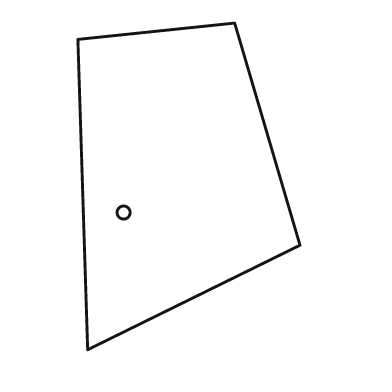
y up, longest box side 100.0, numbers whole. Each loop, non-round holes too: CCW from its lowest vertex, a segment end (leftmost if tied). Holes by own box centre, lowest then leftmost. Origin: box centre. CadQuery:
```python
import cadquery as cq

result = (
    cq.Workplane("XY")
    .moveTo(-31.0, -50.0)
    .lineTo(34.0, -18.0)
    .lineTo(14.0, 50.0)
    .lineTo(-34.0, 45.0)
    .close()
    .moveTo(-20.0, -8.0)
    .circle(2.0)
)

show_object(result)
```